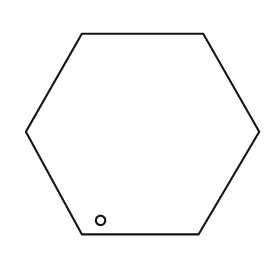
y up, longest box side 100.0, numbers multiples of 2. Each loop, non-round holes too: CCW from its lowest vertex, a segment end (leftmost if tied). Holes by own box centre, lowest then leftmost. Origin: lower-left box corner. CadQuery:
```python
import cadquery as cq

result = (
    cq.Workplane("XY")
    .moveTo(24.0, 0.0)
    .lineTo(74.0, 0.0)
    .lineTo(100.0, 44.0)
    .lineTo(76.0, 86.0)
    .lineTo(24.0, 86.0)
    .lineTo(0.0, 44.0)
    .close()
    .moveTo(32.0, 6.0)
    .circle(2.0)
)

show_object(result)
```